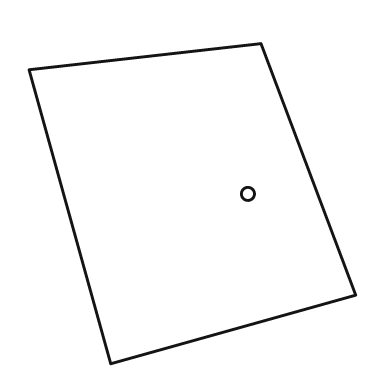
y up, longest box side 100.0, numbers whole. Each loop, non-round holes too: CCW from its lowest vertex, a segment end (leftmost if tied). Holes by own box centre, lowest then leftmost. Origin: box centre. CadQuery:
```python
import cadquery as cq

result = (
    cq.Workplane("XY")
    .moveTo(-25.0, -49.0)
    .lineTo(50.0, -28.0)
    .lineTo(21.0, 49.0)
    .lineTo(-50.0, 41.0)
    .close()
    .moveTo(17.0, 3.0)
    .circle(2.0)
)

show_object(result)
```